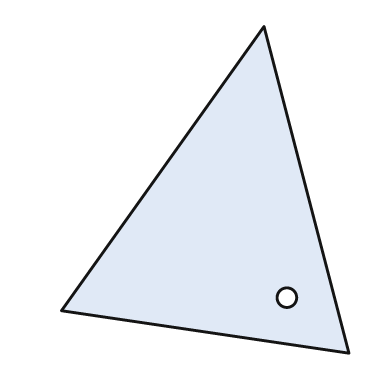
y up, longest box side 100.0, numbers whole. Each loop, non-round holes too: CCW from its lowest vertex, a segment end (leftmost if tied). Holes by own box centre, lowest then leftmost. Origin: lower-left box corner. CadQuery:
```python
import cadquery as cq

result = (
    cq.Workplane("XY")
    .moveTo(88.0, 0.0)
    .lineTo(62.0, 100.0)
    .lineTo(0.0, 13.0)
    .close()
    .moveTo(69.0, 17.0)
    .circle(3.0)
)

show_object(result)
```